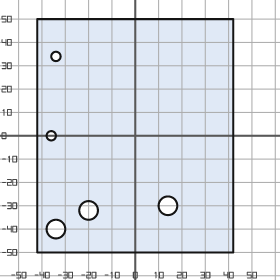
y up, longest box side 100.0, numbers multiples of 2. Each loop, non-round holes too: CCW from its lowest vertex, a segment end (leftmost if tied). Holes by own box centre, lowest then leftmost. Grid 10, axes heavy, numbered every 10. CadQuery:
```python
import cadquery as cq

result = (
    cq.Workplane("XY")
    .moveTo(-42.0, -50.0)
    .lineTo(42.0, -50.0)
    .lineTo(42.0, 50.0)
    .lineTo(-42.0, 50.0)
    .close()
    .moveTo(-34.0, -40.0)
    .circle(4.0)
    .moveTo(-20.0, -32.0)
    .circle(4.0)
    .moveTo(14.0, -30.0)
    .circle(4.0)
    .moveTo(-36.0, 0.0)
    .circle(2.0)
    .moveTo(-34.0, 34.0)
    .circle(2.0)
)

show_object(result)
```